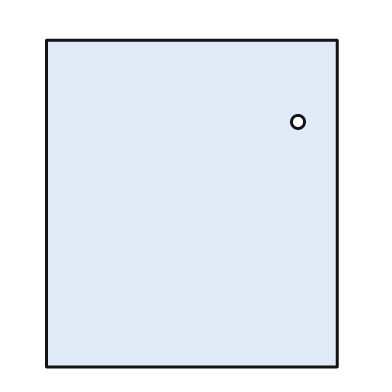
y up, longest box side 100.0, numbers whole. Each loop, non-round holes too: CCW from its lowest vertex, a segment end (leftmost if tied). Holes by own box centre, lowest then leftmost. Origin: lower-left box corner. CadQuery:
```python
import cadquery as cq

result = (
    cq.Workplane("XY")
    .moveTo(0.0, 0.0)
    .lineTo(89.0, 0.0)
    .lineTo(89.0, 100.0)
    .lineTo(0.0, 100.0)
    .close()
    .moveTo(77.0, 75.0)
    .circle(2.0)
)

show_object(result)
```